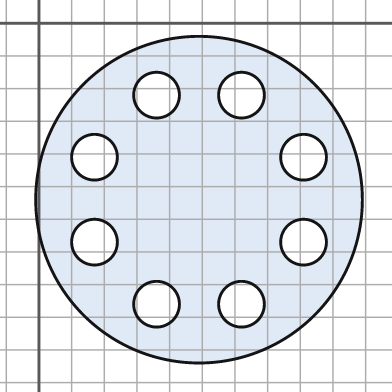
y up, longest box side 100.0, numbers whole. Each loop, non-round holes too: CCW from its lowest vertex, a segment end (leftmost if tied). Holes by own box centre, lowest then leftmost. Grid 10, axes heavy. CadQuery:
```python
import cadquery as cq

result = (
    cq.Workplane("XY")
    .moveTo(49.0, -54.0)
    .circle(50.0)
    .moveTo(36.0, -86.0)
    .circle(7.0)
    .moveTo(62.0, -86.0)
    .circle(7.0)
    .moveTo(17.0, -67.0)
    .circle(7.0)
    .moveTo(81.0, -67.0)
    .circle(7.0)
    .moveTo(17.0, -41.0)
    .circle(7.0)
    .moveTo(81.0, -41.0)
    .circle(7.0)
    .moveTo(36.0, -22.0)
    .circle(7.0)
    .moveTo(62.0, -22.0)
    .circle(7.0)
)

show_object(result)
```